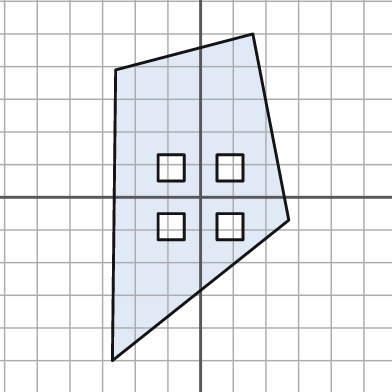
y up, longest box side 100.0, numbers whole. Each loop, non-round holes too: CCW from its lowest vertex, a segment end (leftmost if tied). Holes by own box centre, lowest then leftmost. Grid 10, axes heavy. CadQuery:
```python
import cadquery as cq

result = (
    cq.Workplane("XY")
    .moveTo(-27.0, -50.0)
    .lineTo(27.0, -7.0)
    .lineTo(16.0, 50.0)
    .lineTo(-26.0, 39.0)
    .close()
    .moveTo(-13.0, -13.0)
    .lineTo(-5.0, -13.0)
    .lineTo(-5.0, -5.0)
    .lineTo(-13.0, -5.0)
    .close()
    .moveTo(5.0, -13.0)
    .lineTo(13.0, -13.0)
    .lineTo(13.0, -5.0)
    .lineTo(5.0, -5.0)
    .close()
    .moveTo(-13.0, 5.0)
    .lineTo(-5.0, 5.0)
    .lineTo(-5.0, 13.0)
    .lineTo(-13.0, 13.0)
    .close()
    .moveTo(5.0, 5.0)
    .lineTo(13.0, 5.0)
    .lineTo(13.0, 13.0)
    .lineTo(5.0, 13.0)
    .close()
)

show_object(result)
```